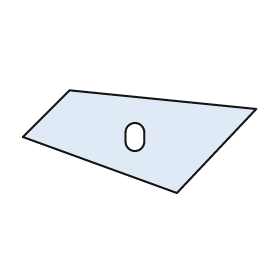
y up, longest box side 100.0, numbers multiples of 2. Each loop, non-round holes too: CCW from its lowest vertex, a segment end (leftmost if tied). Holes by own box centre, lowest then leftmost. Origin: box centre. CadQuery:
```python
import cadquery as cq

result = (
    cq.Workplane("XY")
    .moveTo(16.0, -22.0)
    .lineTo(50.0, 14.0)
    .lineTo(-30.0, 22.0)
    .lineTo(-50.0, 2.0)
    .close()
    .moveTo(-6.0, 0.0)
    .threePointArc((-2.0, -4.0), (2.0, 0.0))
    .lineTo(2.0, 4.0)
    .threePointArc((-2.0, 8.0), (-6.0, 4.0))
    .close()
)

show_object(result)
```